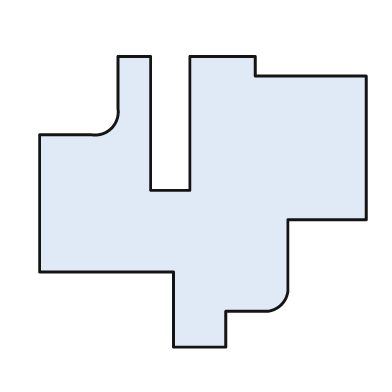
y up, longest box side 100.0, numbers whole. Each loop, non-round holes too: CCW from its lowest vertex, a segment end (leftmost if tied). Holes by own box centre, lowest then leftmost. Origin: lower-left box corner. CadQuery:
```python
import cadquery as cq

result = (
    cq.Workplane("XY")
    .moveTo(41.0, 0.0)
    .lineTo(57.0, 0.0)
    .lineTo(57.0, 11.0)
    .lineTo(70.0, 11.0)
    .threePointArc((74.0, 13.0), (76.0, 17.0))
    .lineTo(76.0, 39.0)
    .lineTo(100.0, 39.0)
    .lineTo(100.0, 83.0)
    .lineTo(66.0, 83.0)
    .lineTo(66.0, 89.0)
    .lineTo(46.0, 89.0)
    .lineTo(46.0, 48.0)
    .lineTo(34.0, 48.0)
    .lineTo(34.0, 89.0)
    .lineTo(24.0, 89.0)
    .lineTo(24.0, 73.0)
    .threePointArc((22.0, 67.0), (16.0, 65.0))
    .lineTo(0.0, 65.0)
    .lineTo(0.0, 23.0)
    .lineTo(41.0, 23.0)
    .close()
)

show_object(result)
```